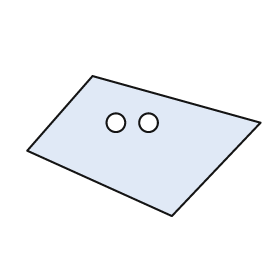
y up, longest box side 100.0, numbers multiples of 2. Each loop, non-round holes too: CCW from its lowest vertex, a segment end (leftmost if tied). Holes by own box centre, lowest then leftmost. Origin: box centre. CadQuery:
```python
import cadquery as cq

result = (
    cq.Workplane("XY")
    .moveTo(12.0, -30.0)
    .lineTo(50.0, 10.0)
    .lineTo(-22.0, 30.0)
    .lineTo(-50.0, -2.0)
    .close()
    .moveTo(-12.0, 10.0)
    .circle(4.0)
    .moveTo(2.0, 10.0)
    .circle(4.0)
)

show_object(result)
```